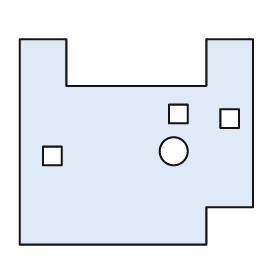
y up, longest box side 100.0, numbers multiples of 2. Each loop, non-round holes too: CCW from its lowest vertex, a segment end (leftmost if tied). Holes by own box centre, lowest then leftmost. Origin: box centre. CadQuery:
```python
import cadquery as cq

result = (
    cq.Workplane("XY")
    .moveTo(-50.0, -44.0)
    .lineTo(30.0, -44.0)
    .lineTo(30.0, -28.0)
    .lineTo(50.0, -28.0)
    .lineTo(50.0, 44.0)
    .lineTo(30.0, 44.0)
    .lineTo(30.0, 24.0)
    .lineTo(-30.0, 24.0)
    .lineTo(-30.0, 44.0)
    .lineTo(-50.0, 44.0)
    .close()
    .moveTo(-40.0, -10.0)
    .lineTo(-32.0, -10.0)
    .lineTo(-32.0, -2.0)
    .lineTo(-40.0, -2.0)
    .close()
    .moveTo(16.0, -4.0)
    .circle(6.0)
    .moveTo(36.0, 6.0)
    .lineTo(44.0, 6.0)
    .lineTo(44.0, 14.0)
    .lineTo(36.0, 14.0)
    .close()
    .moveTo(14.0, 8.0)
    .lineTo(22.0, 8.0)
    .lineTo(22.0, 16.0)
    .lineTo(14.0, 16.0)
    .close()
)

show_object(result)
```